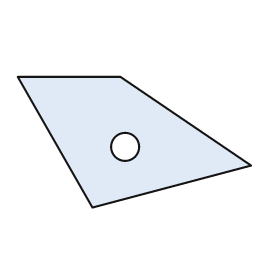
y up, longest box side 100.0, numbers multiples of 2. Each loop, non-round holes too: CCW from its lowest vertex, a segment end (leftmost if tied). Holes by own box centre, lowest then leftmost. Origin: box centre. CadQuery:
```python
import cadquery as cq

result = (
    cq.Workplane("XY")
    .moveTo(-18.0, -28.0)
    .lineTo(50.0, -10.0)
    .lineTo(-6.0, 28.0)
    .lineTo(-50.0, 28.0)
    .close()
    .moveTo(-4.0, -2.0)
    .circle(6.0)
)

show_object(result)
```